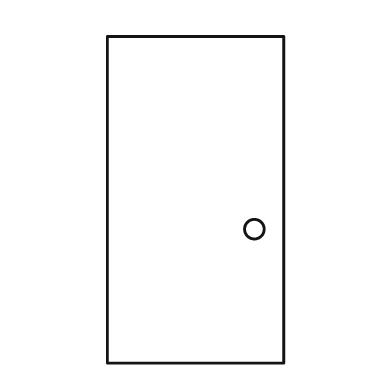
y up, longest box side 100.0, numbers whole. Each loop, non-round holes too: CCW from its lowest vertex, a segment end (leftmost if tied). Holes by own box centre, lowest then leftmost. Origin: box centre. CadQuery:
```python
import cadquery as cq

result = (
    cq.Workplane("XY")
    .moveTo(-27.0, -50.0)
    .lineTo(27.0, -50.0)
    .lineTo(27.0, 50.0)
    .lineTo(-27.0, 50.0)
    .close()
    .moveTo(18.0, -9.0)
    .circle(3.0)
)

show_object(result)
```